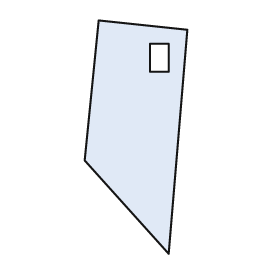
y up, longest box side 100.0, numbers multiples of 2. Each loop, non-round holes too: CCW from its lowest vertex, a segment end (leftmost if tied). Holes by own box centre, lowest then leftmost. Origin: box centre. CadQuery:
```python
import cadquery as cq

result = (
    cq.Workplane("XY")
    .moveTo(14.0, -50.0)
    .lineTo(22.0, 46.0)
    .lineTo(-16.0, 50.0)
    .lineTo(-22.0, -10.0)
    .close()
    .moveTo(6.0, 28.0)
    .lineTo(14.0, 28.0)
    .lineTo(14.0, 40.0)
    .lineTo(6.0, 40.0)
    .close()
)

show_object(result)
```